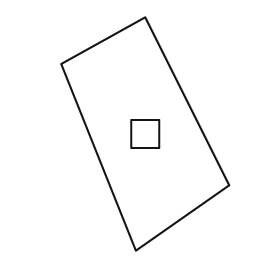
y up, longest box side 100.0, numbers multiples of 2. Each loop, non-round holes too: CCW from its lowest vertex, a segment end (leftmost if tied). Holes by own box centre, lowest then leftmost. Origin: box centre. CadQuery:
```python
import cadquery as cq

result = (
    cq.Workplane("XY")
    .moveTo(-4.0, -50.0)
    .lineTo(36.0, -22.0)
    .lineTo(0.0, 50.0)
    .lineTo(-36.0, 30.0)
    .close()
    .moveTo(-6.0, -6.0)
    .lineTo(6.0, -6.0)
    .lineTo(6.0, 6.0)
    .lineTo(-6.0, 6.0)
    .close()
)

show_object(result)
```